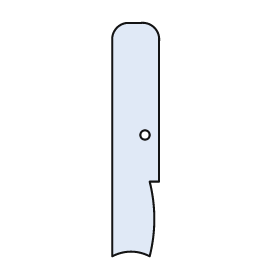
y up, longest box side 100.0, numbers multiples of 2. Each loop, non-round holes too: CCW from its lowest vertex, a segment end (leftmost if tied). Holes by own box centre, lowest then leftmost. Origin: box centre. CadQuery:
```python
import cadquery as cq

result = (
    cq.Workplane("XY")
    .moveTo(-10.0, -50.0)
    .threePointArc((-2.0, -48.0), (6.0, -50.0))
    .threePointArc((8.0, -34.0), (6.0, -18.0))
    .lineTo(10.0, -18.0)
    .lineTo(10.0, 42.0)
    .threePointArc((8.0, 48.0), (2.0, 50.0))
    .lineTo(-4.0, 50.0)
    .threePointArc((-8.0, 48.0), (-10.0, 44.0))
    .close()
    .moveTo(4.0, 2.0)
    .circle(2.0)
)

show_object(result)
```